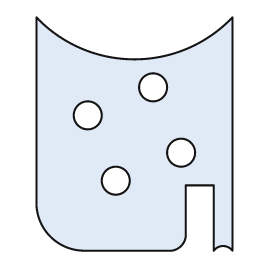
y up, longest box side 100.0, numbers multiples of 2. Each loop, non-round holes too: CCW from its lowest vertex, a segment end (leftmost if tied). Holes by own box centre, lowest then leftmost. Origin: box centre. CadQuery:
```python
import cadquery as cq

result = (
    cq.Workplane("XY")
    .moveTo(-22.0, -50.0)
    .lineTo(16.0, -50.0)
    .threePointArc((20.0, -48.0), (22.0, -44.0))
    .lineTo(22.0, -22.0)
    .lineTo(34.0, -22.0)
    .lineTo(34.0, -50.0)
    .threePointArc((38.0, -48.0), (42.0, -50.0))
    .lineTo(42.0, 50.0)
    .threePointArc((0.0, 32.0), (-42.0, 50.0))
    .lineTo(-42.0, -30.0)
    .threePointArc((-36.0, -44.0), (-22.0, -50.0))
    .close()
    .moveTo(-8.0, -20.0)
    .circle(6.0)
    .moveTo(20.0, -8.0)
    .circle(6.0)
    .moveTo(-20.0, 8.0)
    .circle(6.0)
    .moveTo(8.0, 20.0)
    .circle(6.0)
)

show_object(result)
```